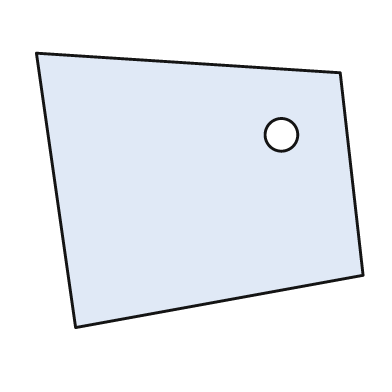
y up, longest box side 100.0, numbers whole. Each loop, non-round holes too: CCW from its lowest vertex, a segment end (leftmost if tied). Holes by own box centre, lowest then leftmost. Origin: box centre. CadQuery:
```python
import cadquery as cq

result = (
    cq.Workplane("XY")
    .moveTo(-38.0, -42.0)
    .lineTo(50.0, -26.0)
    .lineTo(43.0, 36.0)
    .lineTo(-50.0, 42.0)
    .close()
    .moveTo(25.0, 17.0)
    .circle(5.0)
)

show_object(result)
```